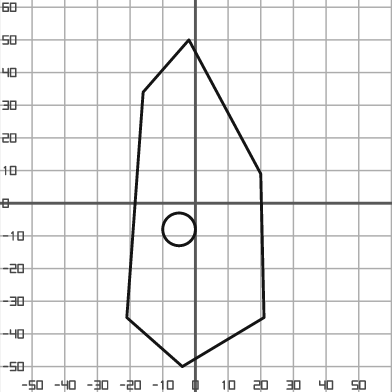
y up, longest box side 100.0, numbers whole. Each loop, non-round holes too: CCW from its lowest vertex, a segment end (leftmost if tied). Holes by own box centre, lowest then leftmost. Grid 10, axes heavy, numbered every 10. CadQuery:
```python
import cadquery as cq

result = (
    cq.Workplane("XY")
    .moveTo(-4.0, -50.0)
    .lineTo(21.0, -35.0)
    .lineTo(20.0, 9.0)
    .lineTo(-2.0, 50.0)
    .lineTo(-16.0, 34.0)
    .lineTo(-21.0, -35.0)
    .close()
    .moveTo(-5.0, -8.0)
    .circle(5.0)
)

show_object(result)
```